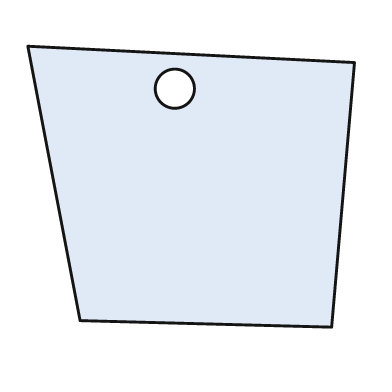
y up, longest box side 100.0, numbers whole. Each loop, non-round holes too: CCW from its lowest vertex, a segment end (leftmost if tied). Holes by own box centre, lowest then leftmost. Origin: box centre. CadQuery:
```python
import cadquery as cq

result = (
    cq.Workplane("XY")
    .moveTo(43.0, -43.0)
    .lineTo(50.0, 38.0)
    .lineTo(-50.0, 43.0)
    .lineTo(-34.0, -41.0)
    .close()
    .moveTo(-5.0, 30.0)
    .circle(6.0)
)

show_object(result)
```